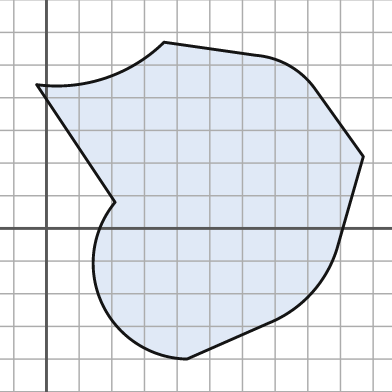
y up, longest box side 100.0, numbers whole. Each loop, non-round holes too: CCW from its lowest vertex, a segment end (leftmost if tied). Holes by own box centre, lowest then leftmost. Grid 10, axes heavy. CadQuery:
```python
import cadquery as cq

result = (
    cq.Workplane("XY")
    .moveTo(43.0, -40.0)
    .lineTo(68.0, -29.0)
    .threePointArc((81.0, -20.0), (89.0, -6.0))
    .lineTo(97.0, 22.0)
    .lineTo(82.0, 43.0)
    .threePointArc((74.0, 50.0), (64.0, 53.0))
    .lineTo(36.0, 57.0)
    .threePointArc((18.0, 46.0), (-3.0, 44.0))
    .lineTo(21.0, 8.0)
    .threePointArc((17.0, -23.0), (43.0, -40.0))
    .close()
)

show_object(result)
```